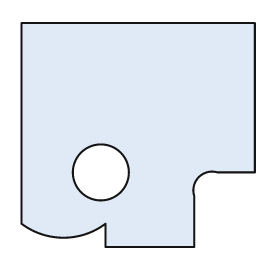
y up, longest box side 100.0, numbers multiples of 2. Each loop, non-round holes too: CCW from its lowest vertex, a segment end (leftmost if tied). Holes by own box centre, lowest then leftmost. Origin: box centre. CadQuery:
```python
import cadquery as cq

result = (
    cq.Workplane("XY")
    .moveTo(-14.0, -48.0)
    .lineTo(24.0, -48.0)
    .lineTo(24.0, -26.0)
    .threePointArc((26.0, -18.0), (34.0, -16.0))
    .lineTo(50.0, -16.0)
    .lineTo(50.0, 48.0)
    .lineTo(-50.0, 48.0)
    .lineTo(-50.0, -38.0)
    .threePointArc((-32.0, -44.0), (-14.0, -38.0))
    .close()
    .moveTo(-16.0, -16.0)
    .circle(12.0)
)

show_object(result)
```